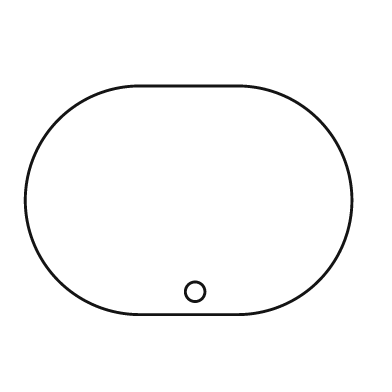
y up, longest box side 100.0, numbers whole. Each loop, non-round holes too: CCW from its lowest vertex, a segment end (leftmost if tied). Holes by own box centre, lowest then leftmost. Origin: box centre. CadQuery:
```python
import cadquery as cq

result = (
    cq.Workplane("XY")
    .moveTo(-15.0, -35.0)
    .lineTo(15.0, -35.0)
    .threePointArc((50.0, 0.0), (15.0, 35.0))
    .lineTo(-15.0, 35.0)
    .threePointArc((-50.0, 0.0), (-15.0, -35.0))
    .close()
    .moveTo(2.0, -28.0)
    .circle(3.0)
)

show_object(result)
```